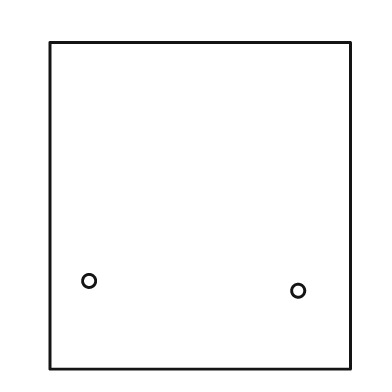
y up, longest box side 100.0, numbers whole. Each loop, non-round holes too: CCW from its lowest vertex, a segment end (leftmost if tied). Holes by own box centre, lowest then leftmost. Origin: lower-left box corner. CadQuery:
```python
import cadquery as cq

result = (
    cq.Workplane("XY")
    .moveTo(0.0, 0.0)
    .lineTo(92.0, 0.0)
    .lineTo(92.0, 100.0)
    .lineTo(0.0, 100.0)
    .close()
    .moveTo(76.0, 24.0)
    .circle(2.0)
    .moveTo(12.0, 27.0)
    .circle(2.0)
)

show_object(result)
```